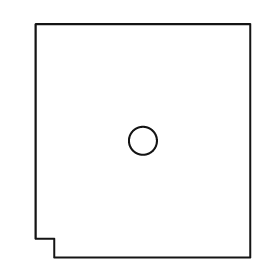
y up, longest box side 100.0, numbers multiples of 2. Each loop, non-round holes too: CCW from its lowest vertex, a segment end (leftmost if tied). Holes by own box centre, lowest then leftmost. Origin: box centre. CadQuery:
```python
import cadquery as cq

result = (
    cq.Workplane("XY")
    .moveTo(-38.0, -50.0)
    .lineTo(46.0, -50.0)
    .lineTo(46.0, 50.0)
    .lineTo(-46.0, 50.0)
    .lineTo(-46.0, -42.0)
    .lineTo(-38.0, -42.0)
    .close()
    .moveTo(0.0, 0.0)
    .circle(6.0)
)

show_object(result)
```